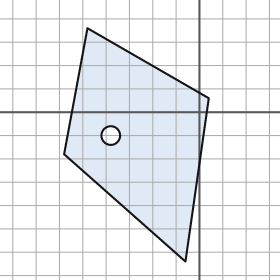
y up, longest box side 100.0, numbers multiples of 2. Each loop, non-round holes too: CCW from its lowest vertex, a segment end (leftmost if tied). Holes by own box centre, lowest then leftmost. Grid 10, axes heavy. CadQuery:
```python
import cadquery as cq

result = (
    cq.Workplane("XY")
    .moveTo(-6.0, -64.0)
    .lineTo(4.0, 6.0)
    .lineTo(-48.0, 36.0)
    .lineTo(-58.0, -18.0)
    .close()
    .moveTo(-38.0, -10.0)
    .circle(4.0)
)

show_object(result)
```